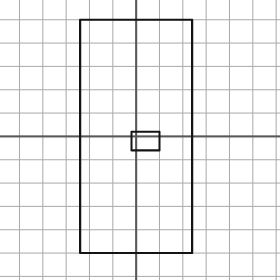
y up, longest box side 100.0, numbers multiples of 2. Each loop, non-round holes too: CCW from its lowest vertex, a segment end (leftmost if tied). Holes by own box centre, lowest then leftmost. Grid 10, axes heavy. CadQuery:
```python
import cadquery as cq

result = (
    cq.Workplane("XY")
    .moveTo(-24.0, -50.0)
    .lineTo(24.0, -50.0)
    .lineTo(24.0, 50.0)
    .lineTo(-24.0, 50.0)
    .close()
    .moveTo(-2.0, -6.0)
    .lineTo(10.0, -6.0)
    .lineTo(10.0, 2.0)
    .lineTo(-2.0, 2.0)
    .close()
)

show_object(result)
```